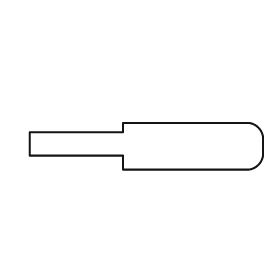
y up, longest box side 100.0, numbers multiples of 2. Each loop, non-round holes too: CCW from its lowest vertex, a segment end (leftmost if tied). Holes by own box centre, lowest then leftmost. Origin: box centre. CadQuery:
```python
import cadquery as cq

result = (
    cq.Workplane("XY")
    .moveTo(-10.0, -10.0)
    .lineTo(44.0, -10.0)
    .threePointArc((48.0, -8.0), (50.0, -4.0))
    .lineTo(50.0, 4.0)
    .threePointArc((48.0, 8.0), (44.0, 10.0))
    .lineTo(-10.0, 10.0)
    .lineTo(-10.0, 6.0)
    .lineTo(-50.0, 6.0)
    .lineTo(-50.0, -4.0)
    .lineTo(-10.0, -4.0)
    .close()
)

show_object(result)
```